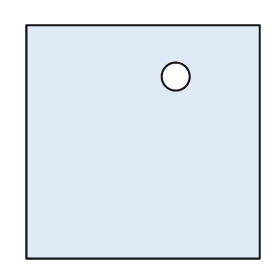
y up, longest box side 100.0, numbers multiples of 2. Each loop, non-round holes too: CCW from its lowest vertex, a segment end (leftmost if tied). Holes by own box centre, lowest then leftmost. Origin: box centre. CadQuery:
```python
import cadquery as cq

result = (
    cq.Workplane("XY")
    .moveTo(-50.0, -50.0)
    .lineTo(50.0, -50.0)
    .lineTo(50.0, 50.0)
    .lineTo(-50.0, 50.0)
    .close()
    .moveTo(14.0, 28.0)
    .circle(6.0)
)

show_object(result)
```